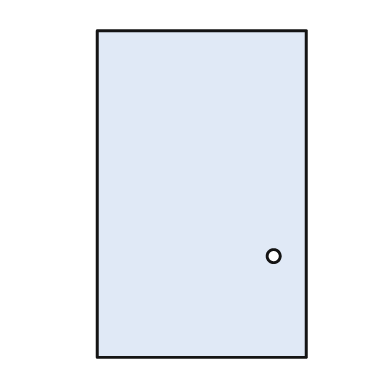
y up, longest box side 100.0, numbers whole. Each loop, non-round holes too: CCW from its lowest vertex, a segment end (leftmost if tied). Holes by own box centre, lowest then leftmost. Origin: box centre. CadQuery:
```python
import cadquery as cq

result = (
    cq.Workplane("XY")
    .moveTo(-32.0, -50.0)
    .lineTo(32.0, -50.0)
    .lineTo(32.0, 50.0)
    .lineTo(-32.0, 50.0)
    .close()
    .moveTo(22.0, -19.0)
    .circle(2.0)
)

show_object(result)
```